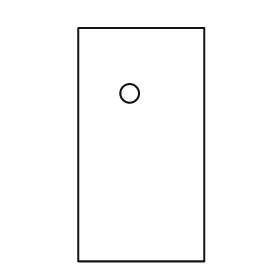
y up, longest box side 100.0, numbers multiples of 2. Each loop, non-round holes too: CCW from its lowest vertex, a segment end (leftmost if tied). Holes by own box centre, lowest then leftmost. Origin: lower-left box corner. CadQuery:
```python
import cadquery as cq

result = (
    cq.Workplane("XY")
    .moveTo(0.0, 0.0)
    .lineTo(54.0, 0.0)
    .lineTo(54.0, 100.0)
    .lineTo(0.0, 100.0)
    .close()
    .moveTo(22.0, 72.0)
    .circle(4.0)
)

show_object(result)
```